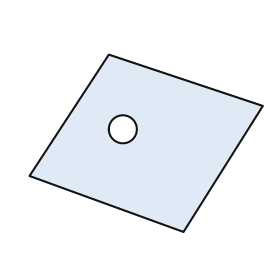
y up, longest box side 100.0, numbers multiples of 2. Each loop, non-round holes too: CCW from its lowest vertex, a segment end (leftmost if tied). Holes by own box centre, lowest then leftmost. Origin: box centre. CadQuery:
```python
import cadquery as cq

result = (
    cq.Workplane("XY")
    .moveTo(16.0, -38.0)
    .lineTo(50.0, 16.0)
    .lineTo(-16.0, 38.0)
    .lineTo(-50.0, -14.0)
    .close()
    .moveTo(-10.0, 6.0)
    .circle(6.0)
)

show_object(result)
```